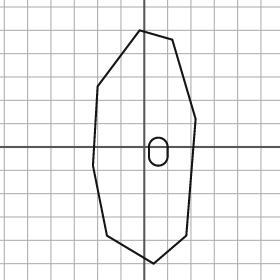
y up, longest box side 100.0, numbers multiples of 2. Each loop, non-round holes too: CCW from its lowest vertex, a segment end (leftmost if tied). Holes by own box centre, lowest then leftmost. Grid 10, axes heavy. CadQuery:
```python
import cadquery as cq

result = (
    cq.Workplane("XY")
    .moveTo(4.0, -50.0)
    .lineTo(18.0, -38.0)
    .lineTo(22.0, 12.0)
    .lineTo(12.0, 46.0)
    .lineTo(-2.0, 50.0)
    .lineTo(-20.0, 26.0)
    .lineTo(-22.0, -8.0)
    .lineTo(-16.0, -38.0)
    .close()
    .moveTo(2.0, -4.0)
    .threePointArc((6.0, -8.0), (10.0, -4.0))
    .lineTo(10.0, 0.0)
    .threePointArc((6.0, 4.0), (2.0, 0.0))
    .close()
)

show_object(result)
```